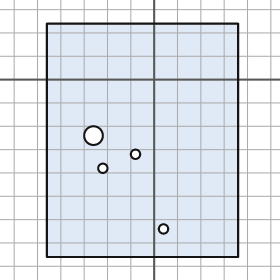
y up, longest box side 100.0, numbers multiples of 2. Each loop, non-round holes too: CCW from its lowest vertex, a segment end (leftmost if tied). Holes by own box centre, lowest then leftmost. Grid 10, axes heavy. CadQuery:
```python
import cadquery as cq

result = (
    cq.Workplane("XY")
    .moveTo(-46.0, -76.0)
    .lineTo(36.0, -76.0)
    .lineTo(36.0, 24.0)
    .lineTo(-46.0, 24.0)
    .close()
    .moveTo(4.0, -64.0)
    .circle(2.0)
    .moveTo(-22.0, -38.0)
    .circle(2.0)
    .moveTo(-8.0, -32.0)
    .circle(2.0)
    .moveTo(-26.0, -24.0)
    .circle(4.0)
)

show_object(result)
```